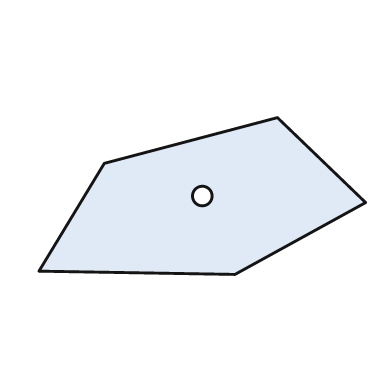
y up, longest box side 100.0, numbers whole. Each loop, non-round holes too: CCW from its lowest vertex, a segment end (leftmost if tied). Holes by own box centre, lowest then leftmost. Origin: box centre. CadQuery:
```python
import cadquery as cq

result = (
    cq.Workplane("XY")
    .moveTo(10.0, -24.0)
    .lineTo(50.0, -2.0)
    .lineTo(23.0, 24.0)
    .lineTo(-30.0, 10.0)
    .lineTo(-50.0, -23.0)
    .close()
    .moveTo(0.0, 0.0)
    .circle(3.0)
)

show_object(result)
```